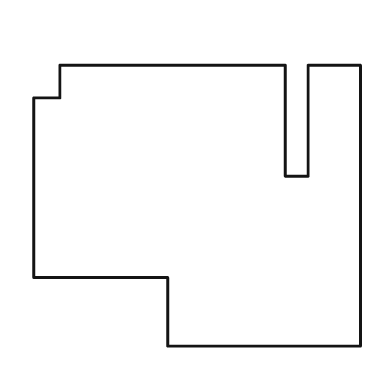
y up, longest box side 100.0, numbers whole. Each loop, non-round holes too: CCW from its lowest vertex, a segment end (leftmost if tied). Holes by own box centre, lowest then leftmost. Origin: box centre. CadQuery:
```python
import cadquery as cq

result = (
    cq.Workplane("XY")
    .moveTo(-9.0, -43.0)
    .lineTo(50.0, -43.0)
    .lineTo(50.0, 43.0)
    .lineTo(34.0, 43.0)
    .lineTo(34.0, 9.0)
    .lineTo(27.0, 9.0)
    .lineTo(27.0, 43.0)
    .lineTo(-42.0, 43.0)
    .lineTo(-42.0, 33.0)
    .lineTo(-50.0, 33.0)
    .lineTo(-50.0, -22.0)
    .lineTo(-9.0, -22.0)
    .close()
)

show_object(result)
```